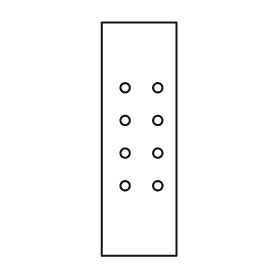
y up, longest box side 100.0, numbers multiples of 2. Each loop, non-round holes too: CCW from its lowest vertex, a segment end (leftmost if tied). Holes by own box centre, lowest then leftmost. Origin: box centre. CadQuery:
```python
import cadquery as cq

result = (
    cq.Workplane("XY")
    .moveTo(-16.0, -50.0)
    .lineTo(16.0, -50.0)
    .lineTo(16.0, 50.0)
    .lineTo(-16.0, 50.0)
    .close()
    .moveTo(-6.0, -20.0)
    .circle(2.0)
    .moveTo(8.0, -20.0)
    .circle(2.0)
    .moveTo(-6.0, -6.0)
    .circle(2.0)
    .moveTo(8.0, -6.0)
    .circle(2.0)
    .moveTo(-6.0, 8.0)
    .circle(2.0)
    .moveTo(8.0, 8.0)
    .circle(2.0)
    .moveTo(-6.0, 22.0)
    .circle(2.0)
    .moveTo(8.0, 22.0)
    .circle(2.0)
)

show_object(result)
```